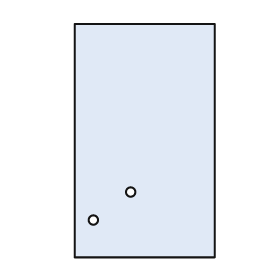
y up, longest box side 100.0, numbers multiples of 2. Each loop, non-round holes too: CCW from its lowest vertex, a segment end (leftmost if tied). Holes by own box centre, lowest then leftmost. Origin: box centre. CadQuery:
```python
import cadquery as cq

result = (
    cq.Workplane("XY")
    .moveTo(-30.0, -50.0)
    .lineTo(30.0, -50.0)
    .lineTo(30.0, 50.0)
    .lineTo(-30.0, 50.0)
    .close()
    .moveTo(-22.0, -34.0)
    .circle(2.0)
    .moveTo(-6.0, -22.0)
    .circle(2.0)
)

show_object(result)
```